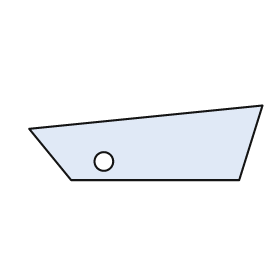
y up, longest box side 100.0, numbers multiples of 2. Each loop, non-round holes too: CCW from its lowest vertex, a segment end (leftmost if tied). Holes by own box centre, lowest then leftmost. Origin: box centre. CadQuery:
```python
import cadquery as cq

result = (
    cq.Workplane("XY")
    .moveTo(-32.0, -16.0)
    .lineTo(40.0, -16.0)
    .lineTo(50.0, 16.0)
    .lineTo(-50.0, 6.0)
    .close()
    .moveTo(-18.0, -8.0)
    .circle(4.0)
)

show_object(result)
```